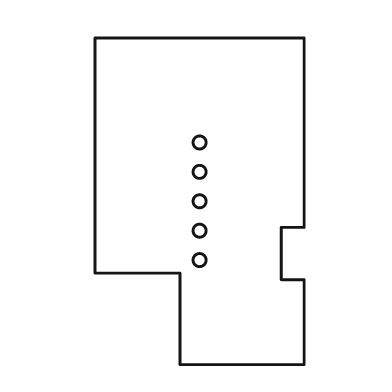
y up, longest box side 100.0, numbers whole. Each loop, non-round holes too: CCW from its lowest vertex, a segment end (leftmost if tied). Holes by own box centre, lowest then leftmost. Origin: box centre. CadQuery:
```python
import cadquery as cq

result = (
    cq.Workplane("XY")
    .moveTo(-6.0, -50.0)
    .lineTo(32.0, -50.0)
    .lineTo(32.0, -24.0)
    .lineTo(25.0, -24.0)
    .lineTo(25.0, -8.0)
    .lineTo(32.0, -8.0)
    .lineTo(32.0, 50.0)
    .lineTo(-32.0, 50.0)
    .lineTo(-32.0, -22.0)
    .lineTo(-6.0, -22.0)
    .close()
    .moveTo(0.0, -18.0)
    .circle(2.0)
    .moveTo(0.0, -9.0)
    .circle(2.0)
    .moveTo(0.0, 0.0)
    .circle(2.0)
    .moveTo(0.0, 9.0)
    .circle(2.0)
    .moveTo(0.0, 18.0)
    .circle(2.0)
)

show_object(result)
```